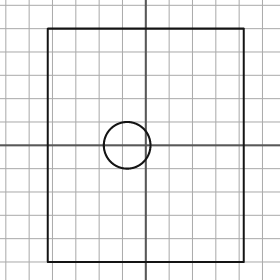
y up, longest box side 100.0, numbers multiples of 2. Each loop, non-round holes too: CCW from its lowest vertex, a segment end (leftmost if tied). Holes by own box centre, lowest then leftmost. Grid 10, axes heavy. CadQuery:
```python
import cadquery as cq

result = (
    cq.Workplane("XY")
    .moveTo(-42.0, -50.0)
    .lineTo(42.0, -50.0)
    .lineTo(42.0, 50.0)
    .lineTo(-42.0, 50.0)
    .close()
    .moveTo(-8.0, 0.0)
    .circle(10.0)
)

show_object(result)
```